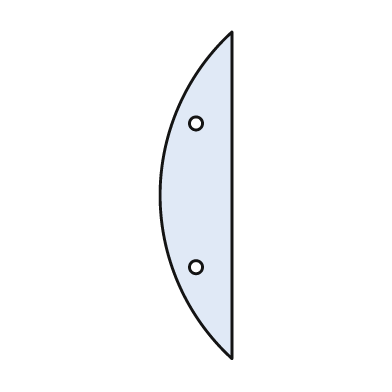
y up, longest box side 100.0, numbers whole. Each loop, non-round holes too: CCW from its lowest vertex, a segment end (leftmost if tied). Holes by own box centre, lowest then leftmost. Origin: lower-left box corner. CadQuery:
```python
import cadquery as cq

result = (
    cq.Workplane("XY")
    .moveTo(22.0, 0.0)
    .lineTo(22.0, 100.0)
    .threePointArc((0.0, 50.0), (22.0, 0.0))
    .close()
    .moveTo(11.0, 28.0)
    .circle(2.0)
    .moveTo(11.0, 72.0)
    .circle(2.0)
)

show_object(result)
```